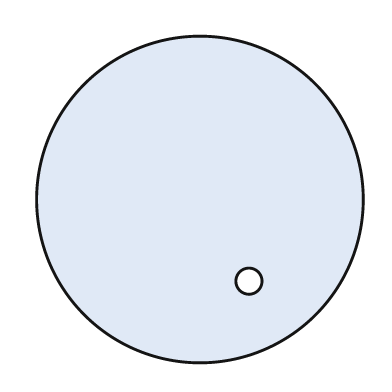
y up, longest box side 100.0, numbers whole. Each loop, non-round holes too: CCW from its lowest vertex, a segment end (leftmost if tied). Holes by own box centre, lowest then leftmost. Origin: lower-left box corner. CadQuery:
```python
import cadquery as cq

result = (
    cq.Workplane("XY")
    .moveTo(50.0, 50.0)
    .circle(50.0)
    .moveTo(65.0, 25.0)
    .circle(4.0)
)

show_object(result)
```